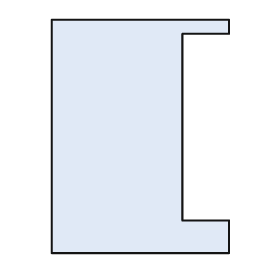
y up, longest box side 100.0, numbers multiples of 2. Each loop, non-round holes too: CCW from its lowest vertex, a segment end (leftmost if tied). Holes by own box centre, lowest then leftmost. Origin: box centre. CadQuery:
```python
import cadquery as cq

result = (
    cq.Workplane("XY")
    .moveTo(-38.0, -50.0)
    .lineTo(38.0, -50.0)
    .lineTo(38.0, -36.0)
    .lineTo(18.0, -36.0)
    .lineTo(18.0, 44.0)
    .lineTo(38.0, 44.0)
    .lineTo(38.0, 50.0)
    .lineTo(-38.0, 50.0)
    .close()
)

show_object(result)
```